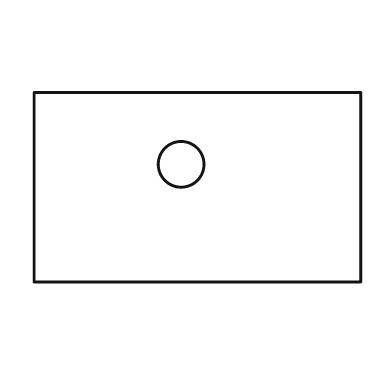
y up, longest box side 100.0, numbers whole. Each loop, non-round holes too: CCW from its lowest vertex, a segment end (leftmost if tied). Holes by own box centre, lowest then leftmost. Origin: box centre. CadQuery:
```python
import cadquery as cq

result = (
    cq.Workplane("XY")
    .moveTo(-50.0, -29.0)
    .lineTo(50.0, -29.0)
    .lineTo(50.0, 29.0)
    .lineTo(-50.0, 29.0)
    .close()
    .moveTo(-5.0, 7.0)
    .circle(7.0)
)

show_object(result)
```